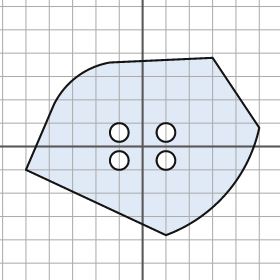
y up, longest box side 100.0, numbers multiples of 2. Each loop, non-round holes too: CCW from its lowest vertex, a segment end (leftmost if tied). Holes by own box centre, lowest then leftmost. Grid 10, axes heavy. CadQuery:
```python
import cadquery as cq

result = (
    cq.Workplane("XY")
    .moveTo(10.0, -38.0)
    .threePointArc((36.0, -20.0), (50.0, 8.0))
    .lineTo(30.0, 38.0)
    .lineTo(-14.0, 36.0)
    .threePointArc((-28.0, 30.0), (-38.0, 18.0))
    .lineTo(-50.0, -10.0)
    .close()
    .moveTo(-10.0, -6.0)
    .circle(4.0)
    .moveTo(10.0, -6.0)
    .circle(4.0)
    .moveTo(-10.0, 6.0)
    .circle(4.0)
    .moveTo(10.0, 6.0)
    .circle(4.0)
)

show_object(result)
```